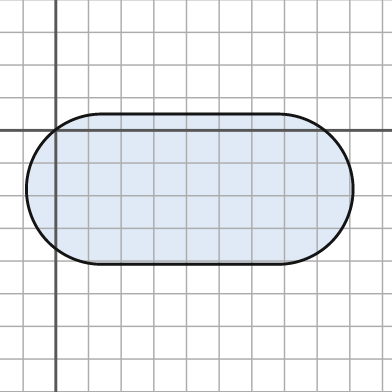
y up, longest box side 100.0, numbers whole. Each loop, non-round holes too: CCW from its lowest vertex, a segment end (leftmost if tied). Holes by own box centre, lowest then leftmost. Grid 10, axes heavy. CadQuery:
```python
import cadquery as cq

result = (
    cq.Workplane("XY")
    .moveTo(14.0, -41.0)
    .lineTo(68.0, -41.0)
    .threePointArc((91.0, -18.0), (68.0, 5.0))
    .lineTo(14.0, 5.0)
    .threePointArc((-9.0, -18.0), (14.0, -41.0))
    .close()
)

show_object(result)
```